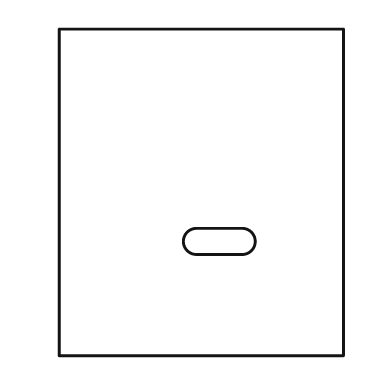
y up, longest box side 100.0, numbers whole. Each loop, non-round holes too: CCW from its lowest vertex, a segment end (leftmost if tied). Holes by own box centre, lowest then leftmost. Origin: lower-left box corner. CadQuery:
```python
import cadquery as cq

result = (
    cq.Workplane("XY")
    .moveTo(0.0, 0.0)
    .lineTo(87.0, 0.0)
    .lineTo(87.0, 100.0)
    .lineTo(0.0, 100.0)
    .close()
    .moveTo(42.0, 31.0)
    .lineTo(56.0, 31.0)
    .threePointArc((60.0, 35.0), (56.0, 39.0))
    .lineTo(42.0, 39.0)
    .threePointArc((38.0, 35.0), (42.0, 31.0))
    .close()
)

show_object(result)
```